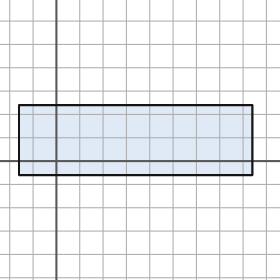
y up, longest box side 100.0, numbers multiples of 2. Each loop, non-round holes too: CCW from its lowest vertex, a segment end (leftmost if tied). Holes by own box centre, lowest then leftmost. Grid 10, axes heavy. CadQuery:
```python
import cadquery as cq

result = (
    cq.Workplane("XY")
    .moveTo(-16.0, -6.0)
    .lineTo(84.0, -6.0)
    .lineTo(84.0, 24.0)
    .lineTo(-16.0, 24.0)
    .close()
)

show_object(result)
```